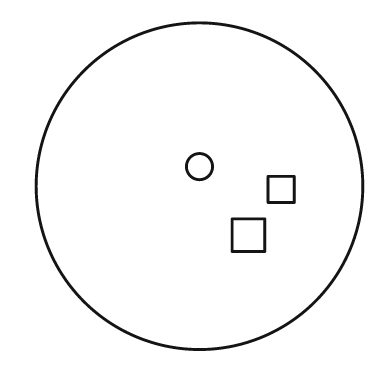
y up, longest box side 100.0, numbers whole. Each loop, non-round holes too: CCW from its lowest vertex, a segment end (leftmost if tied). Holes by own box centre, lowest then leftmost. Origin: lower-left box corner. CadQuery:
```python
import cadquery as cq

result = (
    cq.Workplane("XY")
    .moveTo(50.0, 50.0)
    .circle(50.0)
    .moveTo(60.0, 30.0)
    .lineTo(70.0, 30.0)
    .lineTo(70.0, 40.0)
    .lineTo(60.0, 40.0)
    .close()
    .moveTo(71.0, 45.0)
    .lineTo(79.0, 45.0)
    .lineTo(79.0, 53.0)
    .lineTo(71.0, 53.0)
    .close()
    .moveTo(50.0, 56.0)
    .circle(4.0)
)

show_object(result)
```